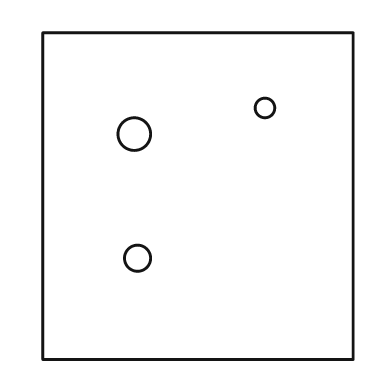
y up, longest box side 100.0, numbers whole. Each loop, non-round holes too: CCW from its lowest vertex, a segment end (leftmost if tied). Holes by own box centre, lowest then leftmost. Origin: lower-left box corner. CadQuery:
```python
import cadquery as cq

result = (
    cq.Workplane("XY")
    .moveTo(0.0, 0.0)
    .lineTo(95.0, 0.0)
    .lineTo(95.0, 100.0)
    .lineTo(0.0, 100.0)
    .close()
    .moveTo(29.0, 31.0)
    .circle(4.0)
    .moveTo(28.0, 69.0)
    .circle(5.0)
    .moveTo(68.0, 77.0)
    .circle(3.0)
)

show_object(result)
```